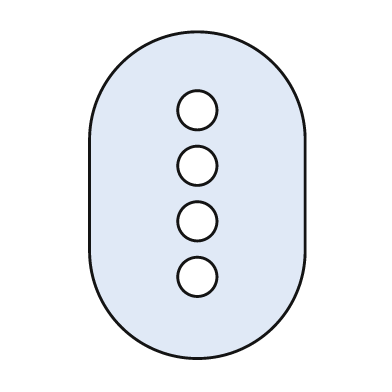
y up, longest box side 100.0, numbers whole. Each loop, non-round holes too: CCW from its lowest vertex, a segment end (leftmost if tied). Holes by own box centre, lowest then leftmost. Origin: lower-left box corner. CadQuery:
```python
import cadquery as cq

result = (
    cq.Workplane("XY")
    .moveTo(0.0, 33.0)
    .threePointArc((33.0, 0.0), (66.0, 33.0))
    .lineTo(66.0, 67.0)
    .threePointArc((33.0, 100.0), (0.0, 67.0))
    .close()
    .moveTo(33.0, 25.0)
    .circle(6.0)
    .moveTo(33.0, 42.0)
    .circle(6.0)
    .moveTo(33.0, 59.0)
    .circle(6.0)
    .moveTo(33.0, 76.0)
    .circle(6.0)
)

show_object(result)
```